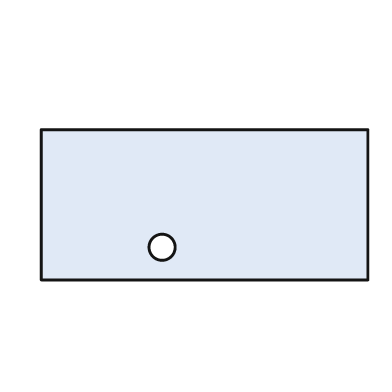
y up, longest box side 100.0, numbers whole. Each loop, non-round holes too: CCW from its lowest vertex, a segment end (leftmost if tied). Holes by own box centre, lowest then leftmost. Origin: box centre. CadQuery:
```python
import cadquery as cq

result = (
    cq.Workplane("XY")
    .moveTo(-50.0, -23.0)
    .lineTo(50.0, -23.0)
    .lineTo(50.0, 23.0)
    .lineTo(-50.0, 23.0)
    .close()
    .moveTo(-13.0, -13.0)
    .circle(4.0)
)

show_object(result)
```